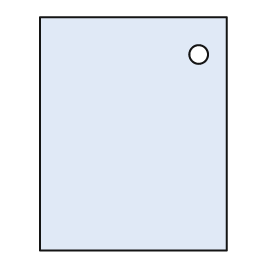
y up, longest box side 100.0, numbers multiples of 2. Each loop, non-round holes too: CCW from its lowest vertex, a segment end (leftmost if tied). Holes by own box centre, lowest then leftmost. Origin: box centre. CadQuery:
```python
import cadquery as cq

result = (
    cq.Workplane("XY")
    .moveTo(-40.0, -50.0)
    .lineTo(40.0, -50.0)
    .lineTo(40.0, 50.0)
    .lineTo(-40.0, 50.0)
    .close()
    .moveTo(28.0, 34.0)
    .circle(4.0)
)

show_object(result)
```